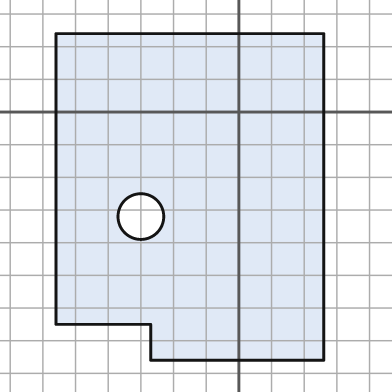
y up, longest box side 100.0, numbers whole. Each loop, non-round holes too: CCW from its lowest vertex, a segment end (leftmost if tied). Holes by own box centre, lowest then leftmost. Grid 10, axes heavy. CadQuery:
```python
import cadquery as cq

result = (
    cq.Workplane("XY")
    .moveTo(-27.0, -76.0)
    .lineTo(26.0, -76.0)
    .lineTo(26.0, 24.0)
    .lineTo(-56.0, 24.0)
    .lineTo(-56.0, -65.0)
    .lineTo(-27.0, -65.0)
    .close()
    .moveTo(-30.0, -32.0)
    .circle(7.0)
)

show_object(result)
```